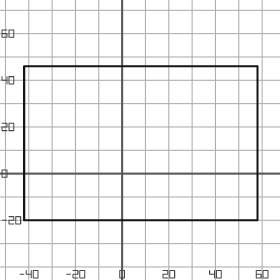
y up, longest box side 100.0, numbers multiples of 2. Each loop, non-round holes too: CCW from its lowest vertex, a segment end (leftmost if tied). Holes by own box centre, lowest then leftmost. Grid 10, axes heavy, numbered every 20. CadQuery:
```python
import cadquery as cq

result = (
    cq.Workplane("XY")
    .moveTo(-42.0, -20.0)
    .lineTo(58.0, -20.0)
    .lineTo(58.0, 46.0)
    .lineTo(-42.0, 46.0)
    .close()
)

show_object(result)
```